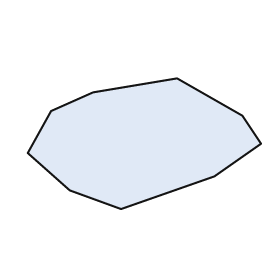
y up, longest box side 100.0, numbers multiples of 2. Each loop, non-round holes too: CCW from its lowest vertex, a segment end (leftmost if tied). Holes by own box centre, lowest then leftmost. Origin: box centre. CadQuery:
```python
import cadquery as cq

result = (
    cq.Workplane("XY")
    .moveTo(-10.0, -28.0)
    .lineTo(30.0, -14.0)
    .lineTo(50.0, 0.0)
    .lineTo(42.0, 12.0)
    .lineTo(14.0, 28.0)
    .lineTo(-22.0, 22.0)
    .lineTo(-40.0, 14.0)
    .lineTo(-50.0, -4.0)
    .lineTo(-32.0, -20.0)
    .close()
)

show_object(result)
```